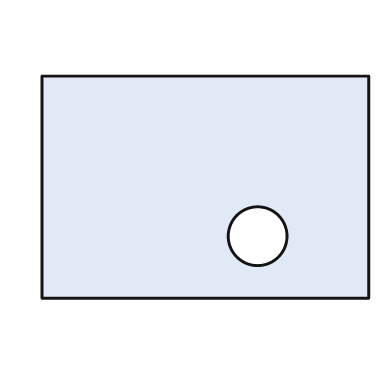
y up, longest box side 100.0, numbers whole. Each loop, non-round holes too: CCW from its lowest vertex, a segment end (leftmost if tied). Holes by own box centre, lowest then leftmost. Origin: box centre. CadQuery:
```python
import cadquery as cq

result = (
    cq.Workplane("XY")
    .moveTo(-50.0, -34.0)
    .lineTo(50.0, -34.0)
    .lineTo(50.0, 34.0)
    .lineTo(-50.0, 34.0)
    .close()
    .moveTo(16.0, -15.0)
    .circle(9.0)
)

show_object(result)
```